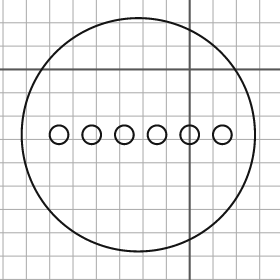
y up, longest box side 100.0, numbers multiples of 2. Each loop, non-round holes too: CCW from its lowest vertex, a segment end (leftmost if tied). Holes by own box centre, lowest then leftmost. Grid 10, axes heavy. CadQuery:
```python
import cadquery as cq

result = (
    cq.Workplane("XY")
    .moveTo(-22.0, -28.0)
    .circle(50.0)
    .moveTo(-56.0, -28.0)
    .circle(4.0)
    .moveTo(-42.0, -28.0)
    .circle(4.0)
    .moveTo(-28.0, -28.0)
    .circle(4.0)
    .moveTo(-14.0, -28.0)
    .circle(4.0)
    .moveTo(0.0, -28.0)
    .circle(4.0)
    .moveTo(14.0, -28.0)
    .circle(4.0)
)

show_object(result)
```